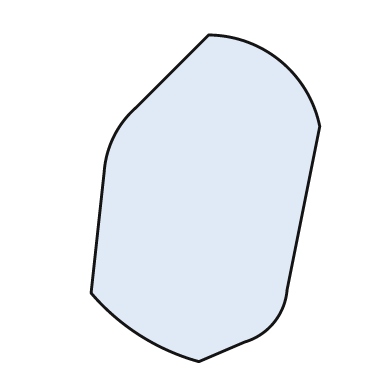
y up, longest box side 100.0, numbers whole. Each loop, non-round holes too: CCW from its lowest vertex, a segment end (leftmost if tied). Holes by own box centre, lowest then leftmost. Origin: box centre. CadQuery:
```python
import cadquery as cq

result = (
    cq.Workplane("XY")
    .moveTo(-2.0, -50.0)
    .lineTo(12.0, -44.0)
    .threePointArc((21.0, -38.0), (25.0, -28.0))
    .lineTo(35.0, 22.0)
    .threePointArc((23.0, 42.0), (1.0, 50.0))
    .lineTo(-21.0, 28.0)
    .threePointArc((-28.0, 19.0), (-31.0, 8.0))
    .lineTo(-35.0, -29.0)
    .threePointArc((-20.0, -42.0), (-2.0, -50.0))
    .close()
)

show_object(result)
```